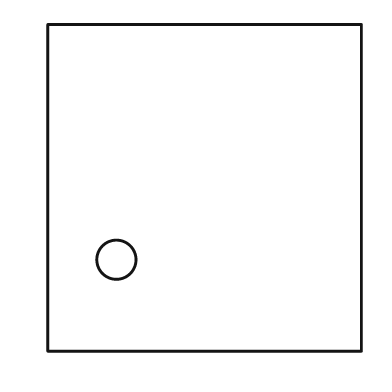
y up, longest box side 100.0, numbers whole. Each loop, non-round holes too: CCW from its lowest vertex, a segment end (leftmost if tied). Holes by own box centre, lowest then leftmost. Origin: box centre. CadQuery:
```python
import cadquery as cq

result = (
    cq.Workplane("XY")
    .moveTo(-48.0, -50.0)
    .lineTo(48.0, -50.0)
    .lineTo(48.0, 50.0)
    .lineTo(-48.0, 50.0)
    .close()
    .moveTo(-27.0, -22.0)
    .circle(6.0)
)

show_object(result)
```